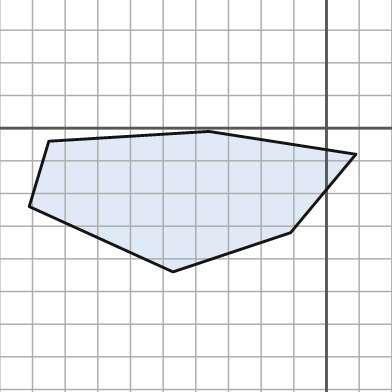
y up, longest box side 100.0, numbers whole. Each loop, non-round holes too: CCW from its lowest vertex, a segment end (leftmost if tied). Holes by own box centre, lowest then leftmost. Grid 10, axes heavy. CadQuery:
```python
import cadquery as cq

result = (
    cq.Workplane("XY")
    .moveTo(-47.0, -44.0)
    .lineTo(-11.0, -32.0)
    .lineTo(9.0, -8.0)
    .lineTo(-36.0, -1.0)
    .lineTo(-85.0, -4.0)
    .lineTo(-91.0, -24.0)
    .close()
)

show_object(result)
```